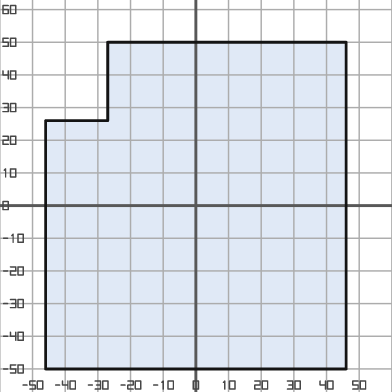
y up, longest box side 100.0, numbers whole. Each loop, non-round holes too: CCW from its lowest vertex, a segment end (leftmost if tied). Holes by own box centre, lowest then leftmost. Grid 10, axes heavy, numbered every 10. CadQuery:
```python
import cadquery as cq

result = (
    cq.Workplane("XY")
    .moveTo(-46.0, -50.0)
    .lineTo(46.0, -50.0)
    .lineTo(46.0, 50.0)
    .lineTo(-27.0, 50.0)
    .lineTo(-27.0, 26.0)
    .lineTo(-46.0, 26.0)
    .close()
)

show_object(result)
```